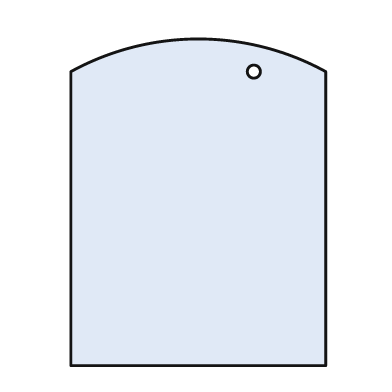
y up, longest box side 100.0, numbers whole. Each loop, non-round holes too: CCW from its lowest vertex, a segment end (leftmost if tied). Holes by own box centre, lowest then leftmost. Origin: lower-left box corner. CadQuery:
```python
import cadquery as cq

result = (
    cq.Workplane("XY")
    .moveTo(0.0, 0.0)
    .lineTo(78.0, 0.0)
    .lineTo(78.0, 90.0)
    .threePointArc((39.0, 100.0), (0.0, 90.0))
    .close()
    .moveTo(56.0, 90.0)
    .circle(2.0)
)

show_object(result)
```